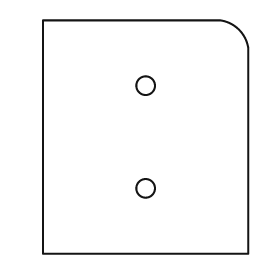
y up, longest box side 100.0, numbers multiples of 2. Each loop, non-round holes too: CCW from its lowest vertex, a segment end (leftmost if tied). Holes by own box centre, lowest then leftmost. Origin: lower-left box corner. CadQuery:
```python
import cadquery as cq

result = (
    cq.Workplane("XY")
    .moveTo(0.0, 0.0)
    .lineTo(88.0, 0.0)
    .lineTo(88.0, 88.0)
    .threePointArc((84.0, 96.0), (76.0, 100.0))
    .lineTo(0.0, 100.0)
    .close()
    .moveTo(44.0, 28.0)
    .circle(4.0)
    .moveTo(44.0, 72.0)
    .circle(4.0)
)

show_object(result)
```